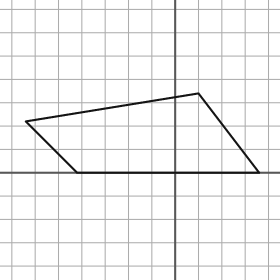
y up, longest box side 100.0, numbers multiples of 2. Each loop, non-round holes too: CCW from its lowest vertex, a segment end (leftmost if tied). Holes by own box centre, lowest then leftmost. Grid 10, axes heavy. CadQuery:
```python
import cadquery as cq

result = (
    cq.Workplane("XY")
    .moveTo(-42.0, 0.0)
    .lineTo(36.0, 0.0)
    .lineTo(10.0, 34.0)
    .lineTo(-64.0, 22.0)
    .close()
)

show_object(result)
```